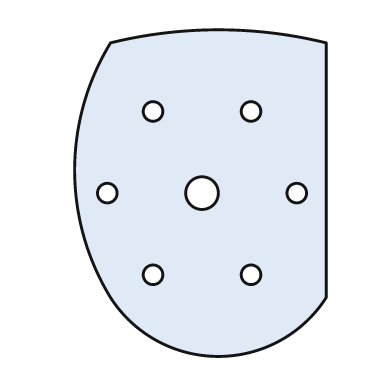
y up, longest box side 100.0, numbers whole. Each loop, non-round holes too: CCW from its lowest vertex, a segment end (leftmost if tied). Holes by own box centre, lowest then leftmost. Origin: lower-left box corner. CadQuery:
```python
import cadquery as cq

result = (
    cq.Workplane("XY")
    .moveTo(11.0, 18.0)
    .threePointArc((44.0, 0.0), (77.0, 18.0))
    .lineTo(77.0, 96.0)
    .threePointArc((44.0, 100.0), (11.0, 96.0))
    .threePointArc((0.0, 57.0), (11.0, 18.0))
    .close()
    .moveTo(24.0, 25.0)
    .circle(3.0)
    .moveTo(54.0, 25.0)
    .circle(3.0)
    .moveTo(10.0, 50.0)
    .circle(3.0)
    .moveTo(39.0, 50.0)
    .circle(5.0)
    .moveTo(68.0, 50.0)
    .circle(3.0)
    .moveTo(24.0, 75.0)
    .circle(3.0)
    .moveTo(54.0, 75.0)
    .circle(3.0)
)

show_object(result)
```